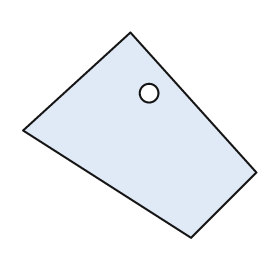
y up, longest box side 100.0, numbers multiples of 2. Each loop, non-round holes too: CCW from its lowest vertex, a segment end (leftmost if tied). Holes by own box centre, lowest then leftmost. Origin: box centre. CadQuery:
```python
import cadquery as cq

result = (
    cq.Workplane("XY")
    .moveTo(22.0, -44.0)
    .lineTo(50.0, -16.0)
    .lineTo(-4.0, 44.0)
    .lineTo(-50.0, 2.0)
    .close()
    .moveTo(4.0, 18.0)
    .circle(4.0)
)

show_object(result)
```